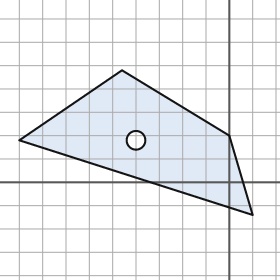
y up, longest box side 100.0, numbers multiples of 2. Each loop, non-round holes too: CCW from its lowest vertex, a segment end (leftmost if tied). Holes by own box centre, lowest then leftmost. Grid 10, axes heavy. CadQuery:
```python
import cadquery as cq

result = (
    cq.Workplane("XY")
    .moveTo(10.0, -14.0)
    .lineTo(0.0, 20.0)
    .lineTo(-46.0, 48.0)
    .lineTo(-90.0, 18.0)
    .close()
    .moveTo(-40.0, 18.0)
    .circle(4.0)
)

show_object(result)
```